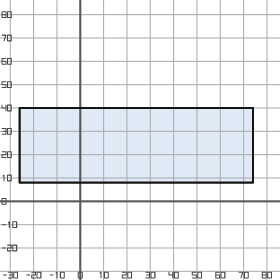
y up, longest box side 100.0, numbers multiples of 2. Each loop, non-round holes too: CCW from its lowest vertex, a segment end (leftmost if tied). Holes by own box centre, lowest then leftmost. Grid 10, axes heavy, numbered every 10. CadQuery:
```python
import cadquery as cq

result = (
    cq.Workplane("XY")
    .moveTo(-26.0, 8.0)
    .lineTo(74.0, 8.0)
    .lineTo(74.0, 40.0)
    .lineTo(-26.0, 40.0)
    .close()
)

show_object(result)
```